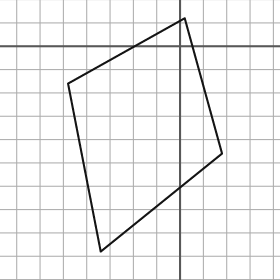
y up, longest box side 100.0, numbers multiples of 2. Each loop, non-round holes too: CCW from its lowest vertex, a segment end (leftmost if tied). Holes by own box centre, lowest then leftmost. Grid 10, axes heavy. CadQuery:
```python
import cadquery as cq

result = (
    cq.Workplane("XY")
    .moveTo(-34.0, -88.0)
    .lineTo(18.0, -46.0)
    .lineTo(2.0, 12.0)
    .lineTo(-48.0, -16.0)
    .close()
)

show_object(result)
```